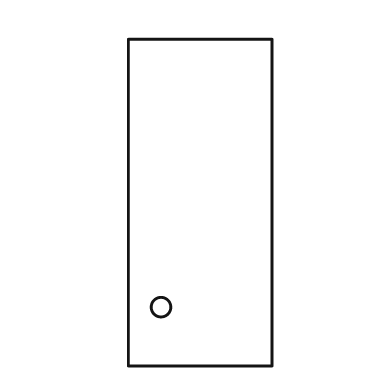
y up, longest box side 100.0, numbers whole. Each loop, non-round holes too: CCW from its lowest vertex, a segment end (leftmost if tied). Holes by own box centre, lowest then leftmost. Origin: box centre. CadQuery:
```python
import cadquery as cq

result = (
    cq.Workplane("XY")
    .moveTo(-22.0, -50.0)
    .lineTo(22.0, -50.0)
    .lineTo(22.0, 50.0)
    .lineTo(-22.0, 50.0)
    .close()
    .moveTo(-12.0, -32.0)
    .circle(3.0)
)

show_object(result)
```